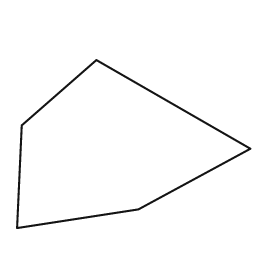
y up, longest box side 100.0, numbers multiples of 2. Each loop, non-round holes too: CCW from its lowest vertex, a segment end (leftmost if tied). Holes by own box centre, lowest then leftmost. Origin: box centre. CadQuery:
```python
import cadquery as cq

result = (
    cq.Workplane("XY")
    .moveTo(-50.0, -36.0)
    .lineTo(2.0, -28.0)
    .lineTo(50.0, -2.0)
    .lineTo(-16.0, 36.0)
    .lineTo(-48.0, 8.0)
    .close()
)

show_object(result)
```